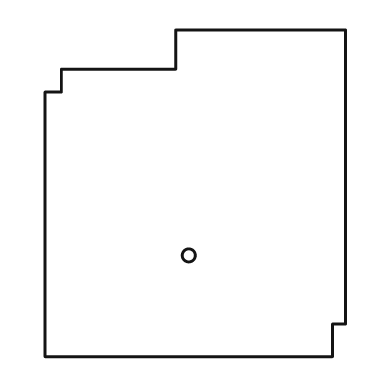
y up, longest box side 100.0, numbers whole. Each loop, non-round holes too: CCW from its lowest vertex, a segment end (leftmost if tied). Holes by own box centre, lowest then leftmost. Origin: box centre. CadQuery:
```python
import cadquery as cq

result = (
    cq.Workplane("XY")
    .moveTo(-46.0, -50.0)
    .lineTo(42.0, -50.0)
    .lineTo(42.0, -40.0)
    .lineTo(46.0, -40.0)
    .lineTo(46.0, 50.0)
    .lineTo(-6.0, 50.0)
    .lineTo(-6.0, 38.0)
    .lineTo(-41.0, 38.0)
    .lineTo(-41.0, 31.0)
    .lineTo(-46.0, 31.0)
    .close()
    .moveTo(-2.0, -19.0)
    .circle(2.0)
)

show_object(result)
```